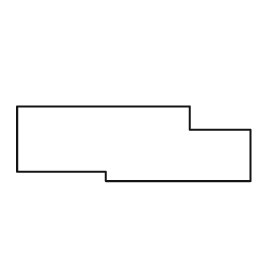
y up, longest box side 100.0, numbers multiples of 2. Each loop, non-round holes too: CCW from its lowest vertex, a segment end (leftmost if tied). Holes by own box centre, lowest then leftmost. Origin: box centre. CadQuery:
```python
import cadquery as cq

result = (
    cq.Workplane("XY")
    .moveTo(-12.0, -16.0)
    .lineTo(50.0, -16.0)
    .lineTo(50.0, 6.0)
    .lineTo(24.0, 6.0)
    .lineTo(24.0, 16.0)
    .lineTo(-50.0, 16.0)
    .lineTo(-50.0, -12.0)
    .lineTo(-12.0, -12.0)
    .close()
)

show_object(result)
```